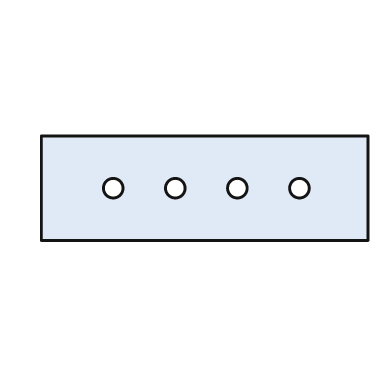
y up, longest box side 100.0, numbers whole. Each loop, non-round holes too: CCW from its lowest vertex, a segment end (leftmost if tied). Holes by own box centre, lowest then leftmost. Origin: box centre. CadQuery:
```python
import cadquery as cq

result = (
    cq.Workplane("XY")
    .moveTo(-50.0, -16.0)
    .lineTo(50.0, -16.0)
    .lineTo(50.0, 16.0)
    .lineTo(-50.0, 16.0)
    .close()
    .moveTo(-28.0, 0.0)
    .circle(3.0)
    .moveTo(-9.0, 0.0)
    .circle(3.0)
    .moveTo(10.0, 0.0)
    .circle(3.0)
    .moveTo(29.0, 0.0)
    .circle(3.0)
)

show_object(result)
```